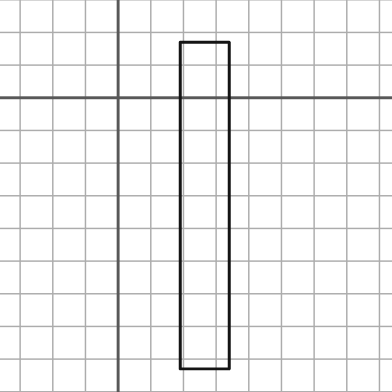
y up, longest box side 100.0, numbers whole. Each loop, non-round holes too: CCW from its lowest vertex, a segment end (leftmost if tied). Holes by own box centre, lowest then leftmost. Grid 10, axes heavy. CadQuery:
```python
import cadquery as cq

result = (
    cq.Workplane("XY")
    .moveTo(19.0, -83.0)
    .lineTo(34.0, -83.0)
    .lineTo(34.0, 17.0)
    .lineTo(19.0, 17.0)
    .close()
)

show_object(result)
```